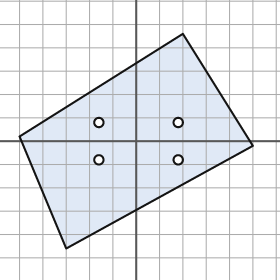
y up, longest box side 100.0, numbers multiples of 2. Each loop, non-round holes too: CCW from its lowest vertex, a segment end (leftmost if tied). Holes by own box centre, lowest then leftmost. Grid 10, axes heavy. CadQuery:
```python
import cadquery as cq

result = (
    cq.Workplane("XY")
    .moveTo(-30.0, -46.0)
    .lineTo(50.0, -2.0)
    .lineTo(20.0, 46.0)
    .lineTo(-50.0, 2.0)
    .close()
    .moveTo(-16.0, -8.0)
    .circle(2.0)
    .moveTo(18.0, -8.0)
    .circle(2.0)
    .moveTo(-16.0, 8.0)
    .circle(2.0)
    .moveTo(18.0, 8.0)
    .circle(2.0)
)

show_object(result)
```